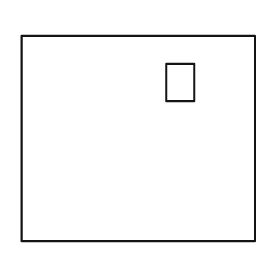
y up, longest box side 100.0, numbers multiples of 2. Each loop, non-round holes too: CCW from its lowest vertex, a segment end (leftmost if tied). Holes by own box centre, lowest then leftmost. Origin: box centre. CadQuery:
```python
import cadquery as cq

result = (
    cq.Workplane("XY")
    .moveTo(-50.0, -44.0)
    .lineTo(50.0, -44.0)
    .lineTo(50.0, 44.0)
    .lineTo(-50.0, 44.0)
    .close()
    .moveTo(12.0, 16.0)
    .lineTo(24.0, 16.0)
    .lineTo(24.0, 32.0)
    .lineTo(12.0, 32.0)
    .close()
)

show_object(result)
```